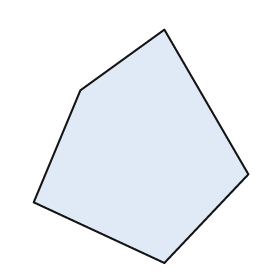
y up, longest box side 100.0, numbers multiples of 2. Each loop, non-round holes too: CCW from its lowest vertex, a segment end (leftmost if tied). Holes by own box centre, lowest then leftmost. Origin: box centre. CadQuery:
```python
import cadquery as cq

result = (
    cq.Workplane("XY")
    .moveTo(10.0, -50.0)
    .lineTo(46.0, -12.0)
    .lineTo(10.0, 50.0)
    .lineTo(-26.0, 24.0)
    .lineTo(-46.0, -24.0)
    .close()
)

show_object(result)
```